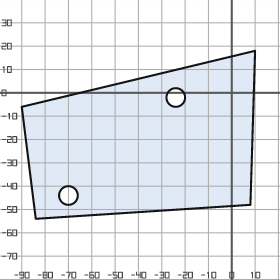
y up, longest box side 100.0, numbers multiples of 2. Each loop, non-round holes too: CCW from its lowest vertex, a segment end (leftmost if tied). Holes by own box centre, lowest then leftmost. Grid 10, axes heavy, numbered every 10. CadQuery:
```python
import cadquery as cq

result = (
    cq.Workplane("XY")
    .moveTo(-84.0, -54.0)
    .lineTo(8.0, -48.0)
    .lineTo(10.0, 18.0)
    .lineTo(-90.0, -6.0)
    .close()
    .moveTo(-70.0, -44.0)
    .circle(4.0)
    .moveTo(-24.0, -2.0)
    .circle(4.0)
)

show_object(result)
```